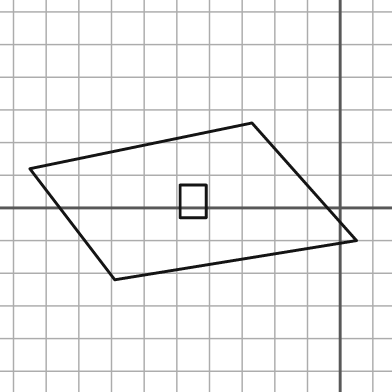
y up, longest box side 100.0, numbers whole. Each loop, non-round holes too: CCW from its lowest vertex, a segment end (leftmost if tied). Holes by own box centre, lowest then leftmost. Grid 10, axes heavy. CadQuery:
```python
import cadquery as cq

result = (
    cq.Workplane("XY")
    .moveTo(-69.0, -22.0)
    .lineTo(5.0, -10.0)
    .lineTo(-27.0, 26.0)
    .lineTo(-95.0, 12.0)
    .close()
    .moveTo(-49.0, -3.0)
    .lineTo(-41.0, -3.0)
    .lineTo(-41.0, 7.0)
    .lineTo(-49.0, 7.0)
    .close()
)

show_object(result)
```